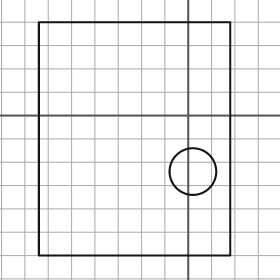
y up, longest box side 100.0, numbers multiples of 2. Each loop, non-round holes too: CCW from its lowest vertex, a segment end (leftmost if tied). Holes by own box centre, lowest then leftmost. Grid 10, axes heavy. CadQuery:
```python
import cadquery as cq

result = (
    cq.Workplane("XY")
    .moveTo(-64.0, -60.0)
    .lineTo(18.0, -60.0)
    .lineTo(18.0, 40.0)
    .lineTo(-64.0, 40.0)
    .close()
    .moveTo(2.0, -24.0)
    .circle(10.0)
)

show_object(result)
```